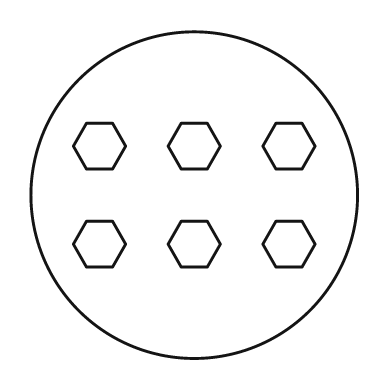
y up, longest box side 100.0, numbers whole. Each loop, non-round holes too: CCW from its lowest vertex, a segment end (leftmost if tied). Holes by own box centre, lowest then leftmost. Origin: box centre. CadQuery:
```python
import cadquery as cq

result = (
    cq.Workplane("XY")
    .moveTo(0.0, 0.0)
    .circle(50.0)
    .moveTo(-33.0, -22.0)
    .lineTo(-25.0, -22.0)
    .lineTo(-21.0, -15.0)
    .lineTo(-25.0, -8.0)
    .lineTo(-33.0, -8.0)
    .lineTo(-37.0, -15.0)
    .close()
    .moveTo(-4.0, -22.0)
    .lineTo(4.0, -22.0)
    .lineTo(8.0, -15.0)
    .lineTo(4.0, -8.0)
    .lineTo(-4.0, -8.0)
    .lineTo(-8.0, -15.0)
    .close()
    .moveTo(25.0, -22.0)
    .lineTo(33.0, -22.0)
    .lineTo(37.0, -15.0)
    .lineTo(33.0, -8.0)
    .lineTo(25.0, -8.0)
    .lineTo(21.0, -15.0)
    .close()
    .moveTo(-33.0, 8.0)
    .lineTo(-25.0, 8.0)
    .lineTo(-21.0, 15.0)
    .lineTo(-25.0, 22.0)
    .lineTo(-33.0, 22.0)
    .lineTo(-37.0, 15.0)
    .close()
    .moveTo(-4.0, 8.0)
    .lineTo(4.0, 8.0)
    .lineTo(8.0, 15.0)
    .lineTo(4.0, 22.0)
    .lineTo(-4.0, 22.0)
    .lineTo(-8.0, 15.0)
    .close()
    .moveTo(25.0, 8.0)
    .lineTo(33.0, 8.0)
    .lineTo(37.0, 15.0)
    .lineTo(33.0, 22.0)
    .lineTo(25.0, 22.0)
    .lineTo(21.0, 15.0)
    .close()
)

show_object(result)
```